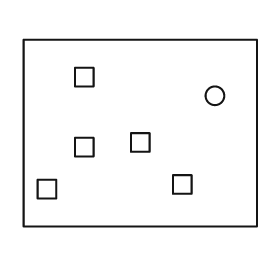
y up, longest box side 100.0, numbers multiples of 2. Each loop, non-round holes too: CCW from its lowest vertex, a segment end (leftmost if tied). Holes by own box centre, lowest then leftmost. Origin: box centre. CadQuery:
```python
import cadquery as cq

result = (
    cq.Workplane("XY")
    .moveTo(-50.0, -40.0)
    .lineTo(50.0, -40.0)
    .lineTo(50.0, 40.0)
    .lineTo(-50.0, 40.0)
    .close()
    .moveTo(-44.0, -28.0)
    .lineTo(-36.0, -28.0)
    .lineTo(-36.0, -20.0)
    .lineTo(-44.0, -20.0)
    .close()
    .moveTo(14.0, -26.0)
    .lineTo(22.0, -26.0)
    .lineTo(22.0, -18.0)
    .lineTo(14.0, -18.0)
    .close()
    .moveTo(-28.0, -10.0)
    .lineTo(-20.0, -10.0)
    .lineTo(-20.0, -2.0)
    .lineTo(-28.0, -2.0)
    .close()
    .moveTo(-4.0, -8.0)
    .lineTo(4.0, -8.0)
    .lineTo(4.0, 0.0)
    .lineTo(-4.0, 0.0)
    .close()
    .moveTo(32.0, 16.0)
    .circle(4.0)
    .moveTo(-28.0, 20.0)
    .lineTo(-20.0, 20.0)
    .lineTo(-20.0, 28.0)
    .lineTo(-28.0, 28.0)
    .close()
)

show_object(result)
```